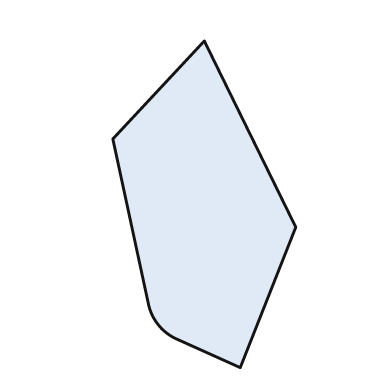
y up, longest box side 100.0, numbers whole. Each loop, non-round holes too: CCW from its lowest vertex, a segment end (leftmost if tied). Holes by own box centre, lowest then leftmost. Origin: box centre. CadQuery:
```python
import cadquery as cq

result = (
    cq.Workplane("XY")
    .moveTo(11.0, -50.0)
    .lineTo(28.0, -7.0)
    .lineTo(0.0, 50.0)
    .lineTo(-28.0, 20.0)
    .lineTo(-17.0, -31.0)
    .threePointArc((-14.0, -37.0), (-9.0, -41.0))
    .close()
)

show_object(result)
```